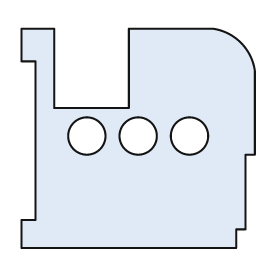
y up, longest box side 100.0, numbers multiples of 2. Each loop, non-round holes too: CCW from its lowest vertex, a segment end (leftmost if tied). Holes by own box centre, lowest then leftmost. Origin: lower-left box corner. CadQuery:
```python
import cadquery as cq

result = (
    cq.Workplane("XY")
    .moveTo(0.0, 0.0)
    .lineTo(92.0, 0.0)
    .lineTo(92.0, 8.0)
    .lineTo(96.0, 8.0)
    .lineTo(96.0, 40.0)
    .lineTo(100.0, 40.0)
    .lineTo(100.0, 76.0)
    .threePointArc((94.0, 88.0), (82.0, 94.0))
    .lineTo(46.0, 94.0)
    .lineTo(46.0, 60.0)
    .lineTo(14.0, 60.0)
    .lineTo(14.0, 94.0)
    .lineTo(0.0, 94.0)
    .lineTo(0.0, 80.0)
    .lineTo(6.0, 80.0)
    .lineTo(6.0, 12.0)
    .lineTo(0.0, 12.0)
    .close()
    .moveTo(28.0, 48.0)
    .circle(8.0)
    .moveTo(50.0, 48.0)
    .circle(8.0)
    .moveTo(72.0, 48.0)
    .circle(8.0)
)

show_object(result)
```